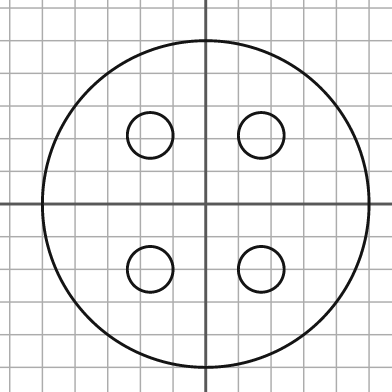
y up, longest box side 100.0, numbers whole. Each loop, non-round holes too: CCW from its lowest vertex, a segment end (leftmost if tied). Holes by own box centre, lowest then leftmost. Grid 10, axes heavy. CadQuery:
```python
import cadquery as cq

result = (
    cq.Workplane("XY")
    .moveTo(0.0, 0.0)
    .circle(50.0)
    .moveTo(-17.0, -20.0)
    .circle(7.0)
    .moveTo(17.0, -20.0)
    .circle(7.0)
    .moveTo(-17.0, 21.0)
    .circle(7.0)
    .moveTo(17.0, 21.0)
    .circle(7.0)
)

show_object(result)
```